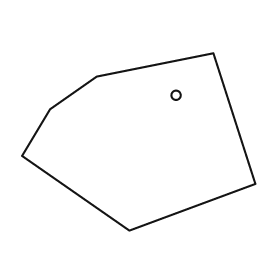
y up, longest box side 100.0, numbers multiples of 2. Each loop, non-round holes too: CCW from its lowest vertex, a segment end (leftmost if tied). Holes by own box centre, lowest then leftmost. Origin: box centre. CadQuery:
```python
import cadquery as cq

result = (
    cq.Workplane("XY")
    .moveTo(-4.0, -38.0)
    .lineTo(50.0, -18.0)
    .lineTo(32.0, 38.0)
    .lineTo(-18.0, 28.0)
    .lineTo(-38.0, 14.0)
    .lineTo(-50.0, -6.0)
    .close()
    .moveTo(16.0, 20.0)
    .circle(2.0)
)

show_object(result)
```